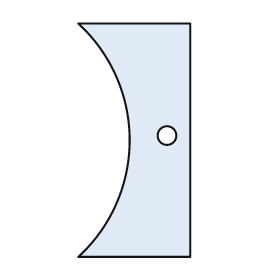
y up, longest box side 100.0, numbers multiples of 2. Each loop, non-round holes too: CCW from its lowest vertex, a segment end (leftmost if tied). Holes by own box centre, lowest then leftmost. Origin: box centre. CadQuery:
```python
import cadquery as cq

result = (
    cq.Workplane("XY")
    .moveTo(-24.0, -50.0)
    .lineTo(24.0, -50.0)
    .lineTo(24.0, 50.0)
    .lineTo(-24.0, 50.0)
    .threePointArc((-2.0, 0.0), (-24.0, -50.0))
    .close()
    .moveTo(14.0, 2.0)
    .circle(4.0)
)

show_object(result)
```